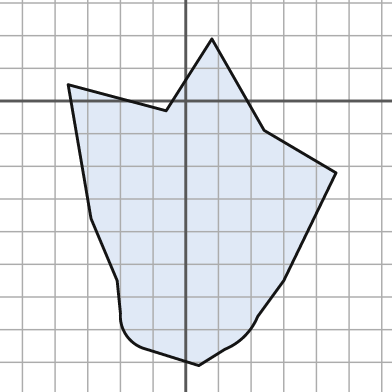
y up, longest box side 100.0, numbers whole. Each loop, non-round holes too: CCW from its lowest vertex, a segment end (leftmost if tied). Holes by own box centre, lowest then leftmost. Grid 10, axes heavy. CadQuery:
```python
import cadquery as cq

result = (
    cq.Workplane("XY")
    .moveTo(4.0, -81.0)
    .lineTo(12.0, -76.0)
    .threePointArc((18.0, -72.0), (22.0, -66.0))
    .lineTo(30.0, -55.0)
    .lineTo(46.0, -22.0)
    .lineTo(24.0, -9.0)
    .lineTo(8.0, 19.0)
    .lineTo(-6.0, -3.0)
    .lineTo(-36.0, 5.0)
    .lineTo(-29.0, -36.0)
    .lineTo(-21.0, -55.0)
    .lineTo(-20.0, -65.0)
    .threePointArc((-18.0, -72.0), (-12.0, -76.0))
    .close()
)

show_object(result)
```